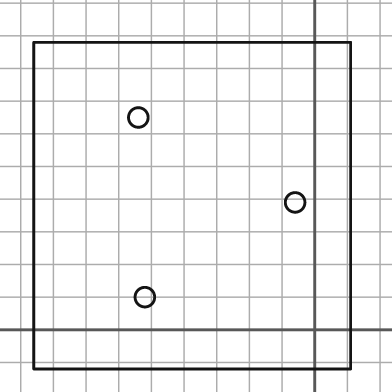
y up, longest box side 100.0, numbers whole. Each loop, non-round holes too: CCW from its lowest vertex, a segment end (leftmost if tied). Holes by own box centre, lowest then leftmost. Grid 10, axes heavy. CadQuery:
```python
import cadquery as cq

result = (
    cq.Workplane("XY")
    .moveTo(-86.0, -12.0)
    .lineTo(11.0, -12.0)
    .lineTo(11.0, 88.0)
    .lineTo(-86.0, 88.0)
    .close()
    .moveTo(-52.0, 10.0)
    .circle(3.0)
    .moveTo(-6.0, 39.0)
    .circle(3.0)
    .moveTo(-54.0, 65.0)
    .circle(3.0)
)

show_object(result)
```